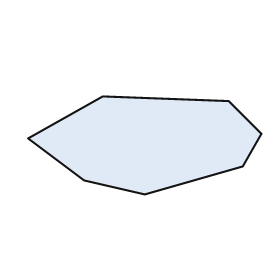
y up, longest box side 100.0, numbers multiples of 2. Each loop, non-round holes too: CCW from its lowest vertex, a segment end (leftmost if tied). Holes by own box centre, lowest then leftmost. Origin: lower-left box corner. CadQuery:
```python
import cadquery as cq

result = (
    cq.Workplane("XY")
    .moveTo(50.0, 0.0)
    .lineTo(92.0, 12.0)
    .lineTo(100.0, 26.0)
    .lineTo(86.0, 40.0)
    .lineTo(32.0, 42.0)
    .lineTo(0.0, 24.0)
    .lineTo(24.0, 6.0)
    .close()
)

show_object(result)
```